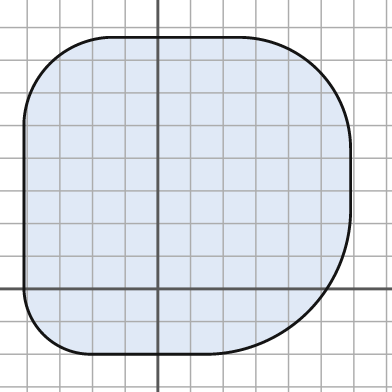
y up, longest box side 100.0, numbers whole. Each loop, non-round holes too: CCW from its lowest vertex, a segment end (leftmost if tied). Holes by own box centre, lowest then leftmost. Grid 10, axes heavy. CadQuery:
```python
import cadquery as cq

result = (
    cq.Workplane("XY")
    .moveTo(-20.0, -20.0)
    .lineTo(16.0, -20.0)
    .threePointArc((46.0, -7.0), (59.0, 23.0))
    .lineTo(59.0, 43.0)
    .threePointArc((49.0, 67.0), (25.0, 77.0))
    .lineTo(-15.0, 77.0)
    .threePointArc((-33.0, 69.0), (-41.0, 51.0))
    .lineTo(-41.0, 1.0)
    .threePointArc((-35.0, -14.0), (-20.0, -20.0))
    .close()
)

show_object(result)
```